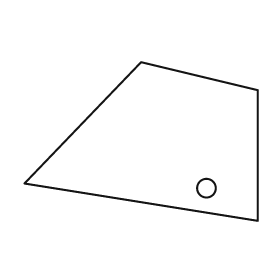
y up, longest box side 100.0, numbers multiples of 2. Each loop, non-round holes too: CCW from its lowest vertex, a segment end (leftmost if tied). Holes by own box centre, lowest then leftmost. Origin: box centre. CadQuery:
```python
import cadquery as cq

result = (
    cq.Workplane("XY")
    .moveTo(50.0, -34.0)
    .lineTo(50.0, 22.0)
    .lineTo(0.0, 34.0)
    .lineTo(-50.0, -18.0)
    .close()
    .moveTo(28.0, -20.0)
    .circle(4.0)
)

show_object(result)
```